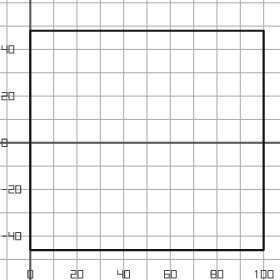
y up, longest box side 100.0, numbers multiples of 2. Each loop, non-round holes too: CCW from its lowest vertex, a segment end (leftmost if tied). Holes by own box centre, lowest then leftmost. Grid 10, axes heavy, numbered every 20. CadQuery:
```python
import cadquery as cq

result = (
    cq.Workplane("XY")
    .moveTo(0.0, -46.0)
    .lineTo(100.0, -46.0)
    .lineTo(100.0, 48.0)
    .lineTo(0.0, 48.0)
    .close()
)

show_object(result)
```